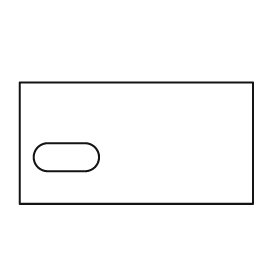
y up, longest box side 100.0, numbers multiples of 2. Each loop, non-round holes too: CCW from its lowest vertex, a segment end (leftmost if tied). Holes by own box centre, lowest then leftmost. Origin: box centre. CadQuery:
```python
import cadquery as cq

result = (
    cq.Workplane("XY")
    .moveTo(-50.0, -26.0)
    .lineTo(50.0, -26.0)
    .lineTo(50.0, 26.0)
    .lineTo(-50.0, 26.0)
    .close()
    .moveTo(-38.0, -12.0)
    .lineTo(-22.0, -12.0)
    .threePointArc((-16.0, -6.0), (-22.0, 0.0))
    .lineTo(-38.0, 0.0)
    .threePointArc((-44.0, -6.0), (-38.0, -12.0))
    .close()
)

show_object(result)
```